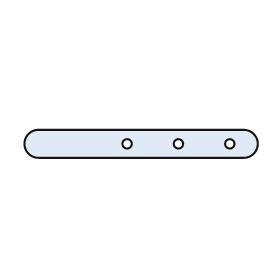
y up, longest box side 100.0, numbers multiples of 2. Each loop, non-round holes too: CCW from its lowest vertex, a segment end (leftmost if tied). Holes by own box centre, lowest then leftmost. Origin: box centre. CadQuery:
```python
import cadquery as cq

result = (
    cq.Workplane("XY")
    .moveTo(-44.0, -6.0)
    .lineTo(44.0, -6.0)
    .threePointArc((50.0, 0.0), (44.0, 6.0))
    .lineTo(-44.0, 6.0)
    .threePointArc((-50.0, 0.0), (-44.0, -6.0))
    .close()
    .moveTo(-6.0, 0.0)
    .circle(2.0)
    .moveTo(16.0, 0.0)
    .circle(2.0)
    .moveTo(38.0, 0.0)
    .circle(2.0)
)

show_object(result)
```